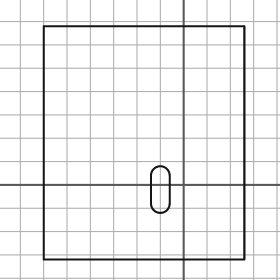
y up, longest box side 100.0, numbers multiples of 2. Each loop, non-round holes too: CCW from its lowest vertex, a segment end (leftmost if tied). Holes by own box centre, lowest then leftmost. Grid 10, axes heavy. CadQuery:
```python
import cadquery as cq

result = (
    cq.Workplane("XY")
    .moveTo(-60.0, -32.0)
    .lineTo(26.0, -32.0)
    .lineTo(26.0, 68.0)
    .lineTo(-60.0, 68.0)
    .close()
    .moveTo(-14.0, -8.0)
    .threePointArc((-10.0, -12.0), (-6.0, -8.0))
    .lineTo(-6.0, 4.0)
    .threePointArc((-10.0, 8.0), (-14.0, 4.0))
    .close()
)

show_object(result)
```